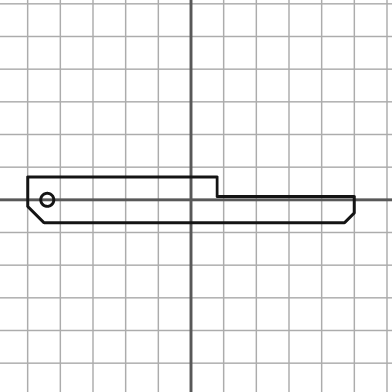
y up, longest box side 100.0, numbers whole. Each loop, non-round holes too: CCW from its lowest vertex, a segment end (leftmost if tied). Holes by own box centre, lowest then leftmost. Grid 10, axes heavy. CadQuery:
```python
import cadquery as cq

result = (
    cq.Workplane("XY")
    .moveTo(-45.0, -7.0)
    .lineTo(47.0, -7.0)
    .lineTo(50.0, -4.0)
    .lineTo(50.0, 1.0)
    .lineTo(8.0, 1.0)
    .lineTo(8.0, 7.0)
    .lineTo(-50.0, 7.0)
    .lineTo(-50.0, -2.0)
    .close()
    .moveTo(-44.0, 0.0)
    .circle(2.0)
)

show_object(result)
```